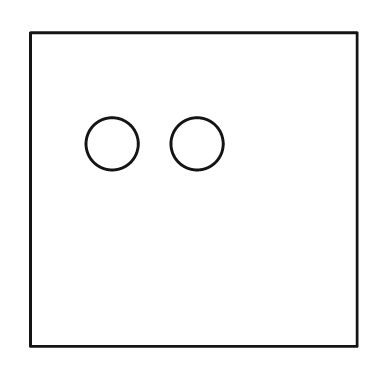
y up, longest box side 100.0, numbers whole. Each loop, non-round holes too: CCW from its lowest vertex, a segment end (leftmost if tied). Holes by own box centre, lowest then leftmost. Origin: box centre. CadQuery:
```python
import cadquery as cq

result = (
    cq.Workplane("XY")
    .moveTo(-50.0, -48.0)
    .lineTo(50.0, -48.0)
    .lineTo(50.0, 48.0)
    .lineTo(-50.0, 48.0)
    .close()
    .moveTo(-25.0, 14.0)
    .circle(8.0)
    .moveTo(1.0, 14.0)
    .circle(8.0)
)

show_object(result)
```